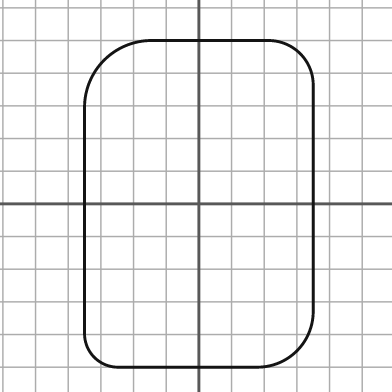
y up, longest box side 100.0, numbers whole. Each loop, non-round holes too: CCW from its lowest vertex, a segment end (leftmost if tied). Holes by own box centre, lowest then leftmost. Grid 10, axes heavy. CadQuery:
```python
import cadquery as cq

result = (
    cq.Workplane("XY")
    .moveTo(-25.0, -50.0)
    .lineTo(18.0, -50.0)
    .threePointArc((30.0, -45.0), (35.0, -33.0))
    .lineTo(35.0, 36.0)
    .threePointArc((31.0, 46.0), (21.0, 50.0))
    .lineTo(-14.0, 50.0)
    .threePointArc((-29.0, 44.0), (-35.0, 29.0))
    .lineTo(-35.0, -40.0)
    .threePointArc((-32.0, -47.0), (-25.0, -50.0))
    .close()
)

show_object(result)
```